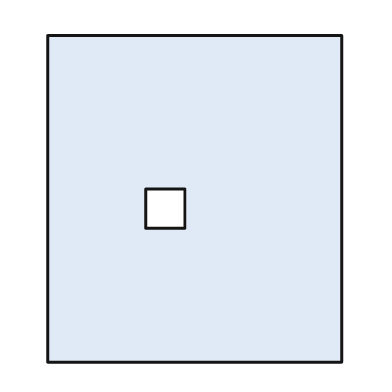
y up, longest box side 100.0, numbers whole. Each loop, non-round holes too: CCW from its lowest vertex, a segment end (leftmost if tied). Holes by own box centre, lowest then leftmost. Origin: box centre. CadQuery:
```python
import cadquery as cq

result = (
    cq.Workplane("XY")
    .moveTo(-45.0, -50.0)
    .lineTo(45.0, -50.0)
    .lineTo(45.0, 50.0)
    .lineTo(-45.0, 50.0)
    .close()
    .moveTo(-15.0, -9.0)
    .lineTo(-3.0, -9.0)
    .lineTo(-3.0, 3.0)
    .lineTo(-15.0, 3.0)
    .close()
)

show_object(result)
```